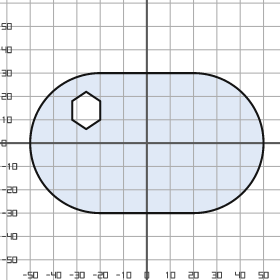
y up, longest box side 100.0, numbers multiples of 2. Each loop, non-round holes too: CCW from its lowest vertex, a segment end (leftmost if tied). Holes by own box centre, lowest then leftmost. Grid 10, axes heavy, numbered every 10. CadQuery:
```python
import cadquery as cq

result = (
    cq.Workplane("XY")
    .moveTo(-20.0, -30.0)
    .lineTo(20.0, -30.0)
    .threePointArc((50.0, 0.0), (20.0, 30.0))
    .lineTo(-20.0, 30.0)
    .threePointArc((-50.0, 0.0), (-20.0, -30.0))
    .close()
    .moveTo(-26.0, 6.0)
    .lineTo(-20.0, 10.0)
    .lineTo(-20.0, 18.0)
    .lineTo(-26.0, 22.0)
    .lineTo(-32.0, 18.0)
    .lineTo(-32.0, 10.0)
    .close()
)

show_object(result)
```